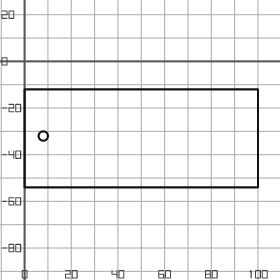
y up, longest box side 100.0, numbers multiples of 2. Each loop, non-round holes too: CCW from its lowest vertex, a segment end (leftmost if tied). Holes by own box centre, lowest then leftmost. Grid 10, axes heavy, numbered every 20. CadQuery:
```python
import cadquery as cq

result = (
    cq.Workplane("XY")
    .moveTo(0.0, -54.0)
    .lineTo(100.0, -54.0)
    .lineTo(100.0, -12.0)
    .lineTo(0.0, -12.0)
    .close()
    .moveTo(8.0, -32.0)
    .circle(2.0)
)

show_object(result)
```